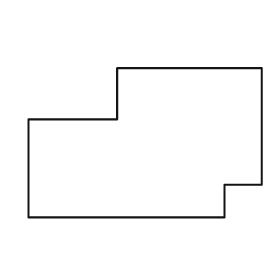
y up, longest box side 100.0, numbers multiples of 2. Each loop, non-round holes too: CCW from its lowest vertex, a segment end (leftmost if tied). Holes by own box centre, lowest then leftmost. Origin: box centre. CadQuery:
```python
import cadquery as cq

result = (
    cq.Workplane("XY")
    .moveTo(-50.0, -32.0)
    .lineTo(34.0, -32.0)
    .lineTo(34.0, -18.0)
    .lineTo(50.0, -18.0)
    .lineTo(50.0, 32.0)
    .lineTo(-12.0, 32.0)
    .lineTo(-12.0, 10.0)
    .lineTo(-50.0, 10.0)
    .close()
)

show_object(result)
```